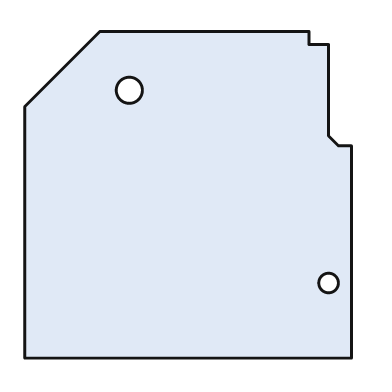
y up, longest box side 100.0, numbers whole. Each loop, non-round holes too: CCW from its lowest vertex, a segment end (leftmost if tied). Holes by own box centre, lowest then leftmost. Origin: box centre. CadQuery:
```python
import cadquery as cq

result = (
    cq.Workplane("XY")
    .moveTo(-50.0, -50.0)
    .lineTo(50.0, -50.0)
    .lineTo(50.0, 15.0)
    .lineTo(46.0, 15.0)
    .lineTo(43.0, 18.0)
    .lineTo(43.0, 46.0)
    .lineTo(37.0, 46.0)
    .lineTo(37.0, 50.0)
    .lineTo(-27.0, 50.0)
    .lineTo(-50.0, 27.0)
    .close()
    .moveTo(43.0, -27.0)
    .circle(3.0)
    .moveTo(-18.0, 32.0)
    .circle(4.0)
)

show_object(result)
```